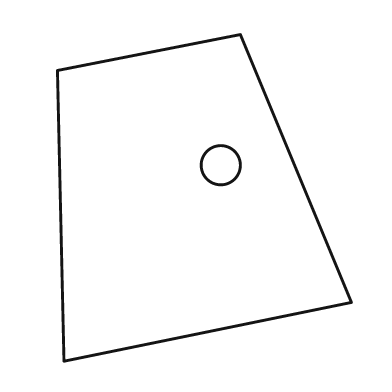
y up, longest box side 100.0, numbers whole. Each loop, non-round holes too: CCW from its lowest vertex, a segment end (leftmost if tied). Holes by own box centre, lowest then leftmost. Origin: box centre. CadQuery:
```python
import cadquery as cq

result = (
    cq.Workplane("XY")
    .moveTo(-43.0, -50.0)
    .lineTo(45.0, -32.0)
    .lineTo(11.0, 50.0)
    .lineTo(-45.0, 39.0)
    .close()
    .moveTo(5.0, 10.0)
    .circle(6.0)
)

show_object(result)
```